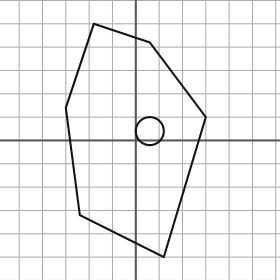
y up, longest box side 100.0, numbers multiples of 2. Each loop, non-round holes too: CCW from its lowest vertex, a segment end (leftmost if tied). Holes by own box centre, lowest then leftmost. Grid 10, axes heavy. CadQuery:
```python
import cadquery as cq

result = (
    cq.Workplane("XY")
    .moveTo(12.0, -50.0)
    .lineTo(30.0, 10.0)
    .lineTo(6.0, 42.0)
    .lineTo(-18.0, 50.0)
    .lineTo(-30.0, 14.0)
    .lineTo(-24.0, -32.0)
    .close()
    .moveTo(6.0, 4.0)
    .circle(6.0)
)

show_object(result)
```